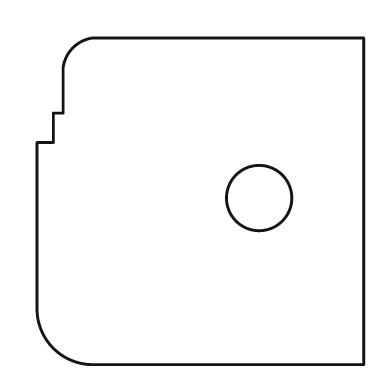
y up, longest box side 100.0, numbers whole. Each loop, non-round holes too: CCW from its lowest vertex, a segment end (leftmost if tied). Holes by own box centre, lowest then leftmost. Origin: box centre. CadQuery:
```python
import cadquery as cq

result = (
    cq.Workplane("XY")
    .moveTo(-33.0, -50.0)
    .lineTo(50.0, -50.0)
    .lineTo(50.0, 50.0)
    .lineTo(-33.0, 50.0)
    .threePointArc((-39.0, 47.0), (-42.0, 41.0))
    .lineTo(-42.0, 27.0)
    .lineTo(-45.0, 27.0)
    .lineTo(-45.0, 18.0)
    .lineTo(-50.0, 18.0)
    .lineTo(-50.0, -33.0)
    .threePointArc((-45.0, -45.0), (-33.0, -50.0))
    .close()
    .moveTo(18.0, 1.0)
    .circle(10.0)
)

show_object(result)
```